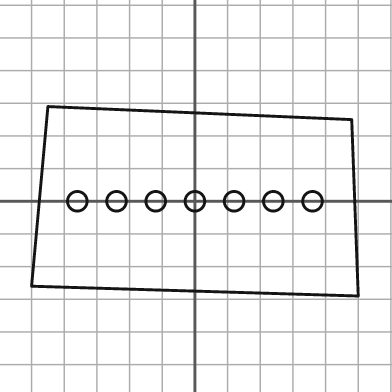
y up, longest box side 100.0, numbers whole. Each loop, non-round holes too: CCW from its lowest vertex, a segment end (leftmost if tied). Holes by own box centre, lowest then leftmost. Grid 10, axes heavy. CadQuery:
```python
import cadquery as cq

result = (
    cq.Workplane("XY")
    .moveTo(50.0, -29.0)
    .lineTo(48.0, 25.0)
    .lineTo(-45.0, 29.0)
    .lineTo(-50.0, -26.0)
    .close()
    .moveTo(-36.0, 0.0)
    .circle(3.0)
    .moveTo(-24.0, 0.0)
    .circle(3.0)
    .moveTo(-12.0, 0.0)
    .circle(3.0)
    .moveTo(0.0, 0.0)
    .circle(3.0)
    .moveTo(12.0, 0.0)
    .circle(3.0)
    .moveTo(24.0, 0.0)
    .circle(3.0)
    .moveTo(36.0, 0.0)
    .circle(3.0)
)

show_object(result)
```